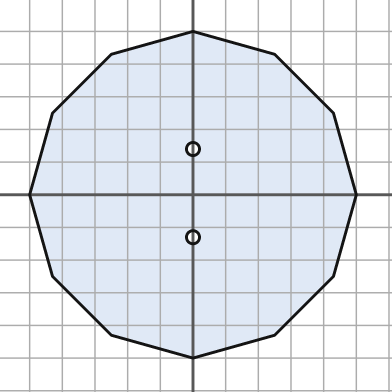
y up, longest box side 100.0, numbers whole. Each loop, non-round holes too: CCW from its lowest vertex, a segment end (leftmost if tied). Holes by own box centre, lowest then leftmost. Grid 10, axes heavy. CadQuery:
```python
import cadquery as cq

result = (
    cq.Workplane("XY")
    .moveTo(0.0, -50.0)
    .lineTo(25.0, -43.0)
    .lineTo(43.0, -25.0)
    .lineTo(50.0, 0.0)
    .lineTo(43.0, 25.0)
    .lineTo(25.0, 43.0)
    .lineTo(0.0, 50.0)
    .lineTo(-25.0, 43.0)
    .lineTo(-43.0, 25.0)
    .lineTo(-50.0, 0.0)
    .lineTo(-43.0, -25.0)
    .lineTo(-25.0, -43.0)
    .close()
    .moveTo(0.0, -13.0)
    .circle(2.0)
    .moveTo(0.0, 14.0)
    .circle(2.0)
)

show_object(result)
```